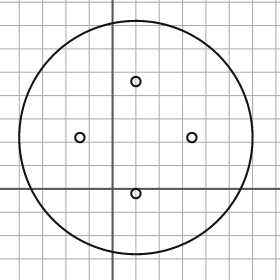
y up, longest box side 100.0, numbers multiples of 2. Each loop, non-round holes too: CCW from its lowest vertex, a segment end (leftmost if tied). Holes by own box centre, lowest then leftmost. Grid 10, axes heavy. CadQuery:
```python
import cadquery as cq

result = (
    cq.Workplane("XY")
    .moveTo(10.0, 22.0)
    .circle(50.0)
    .moveTo(10.0, -2.0)
    .circle(2.0)
    .moveTo(-14.0, 22.0)
    .circle(2.0)
    .moveTo(34.0, 22.0)
    .circle(2.0)
    .moveTo(10.0, 46.0)
    .circle(2.0)
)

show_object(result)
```